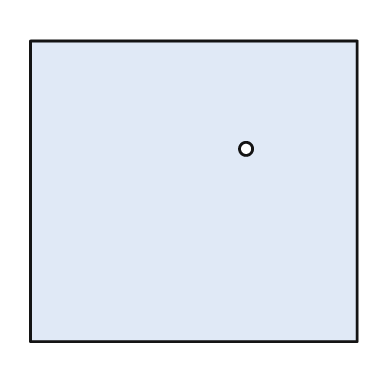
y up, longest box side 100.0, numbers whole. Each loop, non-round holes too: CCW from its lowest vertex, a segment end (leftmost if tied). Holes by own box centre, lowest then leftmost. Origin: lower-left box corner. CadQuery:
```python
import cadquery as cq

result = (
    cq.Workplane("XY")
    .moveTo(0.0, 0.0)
    .lineTo(100.0, 0.0)
    .lineTo(100.0, 92.0)
    .lineTo(0.0, 92.0)
    .close()
    .moveTo(66.0, 59.0)
    .circle(2.0)
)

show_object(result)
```